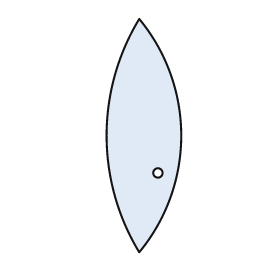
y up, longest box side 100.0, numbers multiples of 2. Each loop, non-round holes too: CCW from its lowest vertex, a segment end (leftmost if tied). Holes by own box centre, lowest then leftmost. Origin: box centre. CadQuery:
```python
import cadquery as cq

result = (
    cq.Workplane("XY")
    .moveTo(-2.0, -50.0)
    .threePointArc((16.0, 0.0), (-2.0, 50.0))
    .threePointArc((-16.0, 0.0), (-2.0, -50.0))
    .close()
    .moveTo(6.0, -16.0)
    .circle(2.0)
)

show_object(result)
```